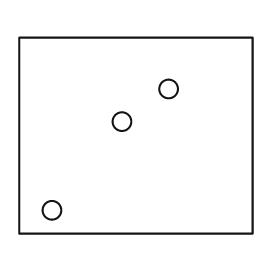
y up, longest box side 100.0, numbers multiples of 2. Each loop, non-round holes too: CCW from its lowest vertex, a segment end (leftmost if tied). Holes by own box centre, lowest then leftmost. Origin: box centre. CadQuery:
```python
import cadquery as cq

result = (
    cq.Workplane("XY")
    .moveTo(-50.0, -42.0)
    .lineTo(50.0, -42.0)
    .lineTo(50.0, 42.0)
    .lineTo(-50.0, 42.0)
    .close()
    .moveTo(-36.0, -32.0)
    .circle(4.0)
    .moveTo(-6.0, 6.0)
    .circle(4.0)
    .moveTo(14.0, 20.0)
    .circle(4.0)
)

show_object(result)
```